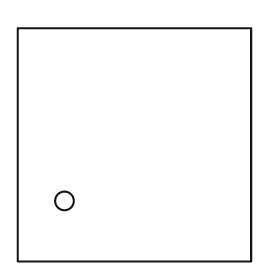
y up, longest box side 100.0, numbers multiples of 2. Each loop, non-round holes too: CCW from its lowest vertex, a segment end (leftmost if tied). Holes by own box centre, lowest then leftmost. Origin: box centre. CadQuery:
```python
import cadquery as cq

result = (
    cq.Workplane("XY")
    .moveTo(-50.0, -50.0)
    .lineTo(50.0, -50.0)
    .lineTo(50.0, 50.0)
    .lineTo(-50.0, 50.0)
    .close()
    .moveTo(-30.0, -24.0)
    .circle(4.0)
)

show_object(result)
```